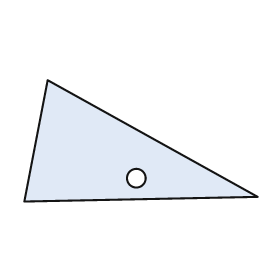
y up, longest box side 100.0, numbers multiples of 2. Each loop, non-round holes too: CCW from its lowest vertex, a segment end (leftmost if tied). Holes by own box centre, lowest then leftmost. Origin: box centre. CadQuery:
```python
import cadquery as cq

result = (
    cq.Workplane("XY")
    .moveTo(-50.0, -26.0)
    .lineTo(50.0, -24.0)
    .lineTo(-40.0, 26.0)
    .close()
    .moveTo(-2.0, -16.0)
    .circle(4.0)
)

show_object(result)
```